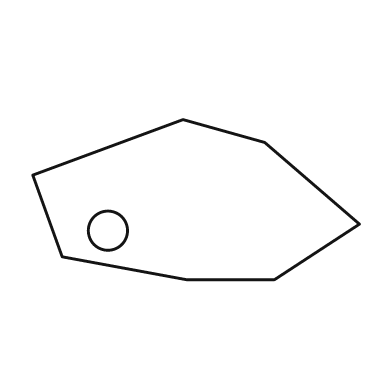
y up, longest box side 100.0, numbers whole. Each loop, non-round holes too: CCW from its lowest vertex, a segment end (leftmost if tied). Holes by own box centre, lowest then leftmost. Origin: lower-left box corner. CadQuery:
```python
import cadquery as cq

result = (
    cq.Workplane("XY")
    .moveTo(47.0, 0.0)
    .lineTo(74.0, 0.0)
    .lineTo(100.0, 17.0)
    .lineTo(71.0, 42.0)
    .lineTo(46.0, 49.0)
    .lineTo(0.0, 32.0)
    .lineTo(9.0, 7.0)
    .close()
    .moveTo(23.0, 15.0)
    .circle(6.0)
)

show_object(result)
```